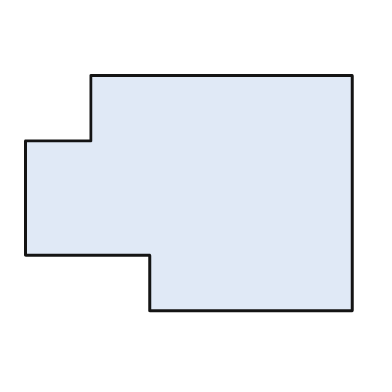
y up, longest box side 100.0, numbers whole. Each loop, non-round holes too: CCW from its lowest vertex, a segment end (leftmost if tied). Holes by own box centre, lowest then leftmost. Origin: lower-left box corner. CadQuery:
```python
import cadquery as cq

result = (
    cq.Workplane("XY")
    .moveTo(38.0, 0.0)
    .lineTo(100.0, 0.0)
    .lineTo(100.0, 72.0)
    .lineTo(20.0, 72.0)
    .lineTo(20.0, 52.0)
    .lineTo(0.0, 52.0)
    .lineTo(0.0, 17.0)
    .lineTo(38.0, 17.0)
    .close()
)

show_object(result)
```